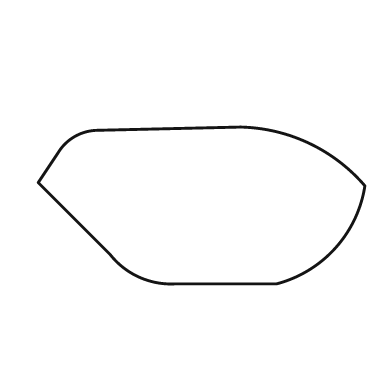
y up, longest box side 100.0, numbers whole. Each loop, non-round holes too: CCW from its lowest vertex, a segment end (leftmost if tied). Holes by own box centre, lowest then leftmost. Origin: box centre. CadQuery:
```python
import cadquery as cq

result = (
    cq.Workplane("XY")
    .moveTo(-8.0, -24.0)
    .lineTo(23.0, -24.0)
    .threePointArc((41.0, -13.0), (50.0, 6.0))
    .threePointArc((33.0, 19.0), (12.0, 24.0))
    .lineTo(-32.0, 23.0)
    .threePointArc((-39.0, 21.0), (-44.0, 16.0))
    .lineTo(-50.0, 7.0)
    .lineTo(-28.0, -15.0)
    .threePointArc((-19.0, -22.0), (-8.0, -24.0))
    .close()
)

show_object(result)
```